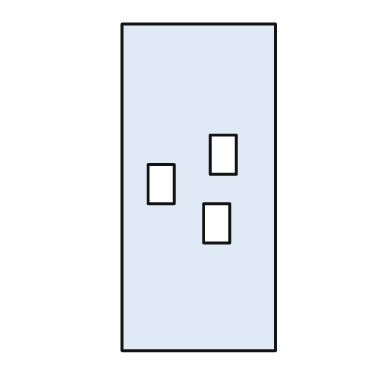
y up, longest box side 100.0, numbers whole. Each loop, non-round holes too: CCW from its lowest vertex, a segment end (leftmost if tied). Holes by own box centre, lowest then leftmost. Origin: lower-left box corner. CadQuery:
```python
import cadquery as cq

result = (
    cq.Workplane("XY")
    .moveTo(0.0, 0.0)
    .lineTo(47.0, 0.0)
    .lineTo(47.0, 100.0)
    .lineTo(0.0, 100.0)
    .close()
    .moveTo(25.0, 33.0)
    .lineTo(33.0, 33.0)
    .lineTo(33.0, 45.0)
    .lineTo(25.0, 45.0)
    .close()
    .moveTo(8.0, 45.0)
    .lineTo(16.0, 45.0)
    .lineTo(16.0, 57.0)
    .lineTo(8.0, 57.0)
    .close()
    .moveTo(27.0, 54.0)
    .lineTo(35.0, 54.0)
    .lineTo(35.0, 66.0)
    .lineTo(27.0, 66.0)
    .close()
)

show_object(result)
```